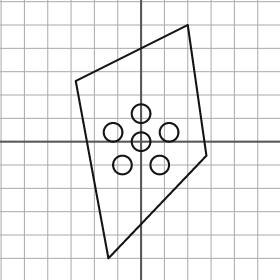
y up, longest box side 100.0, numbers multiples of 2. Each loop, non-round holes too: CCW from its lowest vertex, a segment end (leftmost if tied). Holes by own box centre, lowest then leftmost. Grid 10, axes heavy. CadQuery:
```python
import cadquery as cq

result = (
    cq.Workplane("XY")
    .moveTo(-14.0, -50.0)
    .lineTo(28.0, -6.0)
    .lineTo(20.0, 50.0)
    .lineTo(-28.0, 26.0)
    .close()
    .moveTo(-8.0, -10.0)
    .circle(4.0)
    .moveTo(8.0, -10.0)
    .circle(4.0)
    .moveTo(0.0, 0.0)
    .circle(4.0)
    .moveTo(-12.0, 4.0)
    .circle(4.0)
    .moveTo(12.0, 4.0)
    .circle(4.0)
    .moveTo(0.0, 12.0)
    .circle(4.0)
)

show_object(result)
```